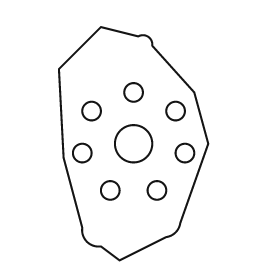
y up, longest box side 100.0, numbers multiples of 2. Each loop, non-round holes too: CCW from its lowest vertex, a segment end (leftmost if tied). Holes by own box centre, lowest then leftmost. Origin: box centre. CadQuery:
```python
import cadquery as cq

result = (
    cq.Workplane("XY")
    .moveTo(-6.0, -50.0)
    .lineTo(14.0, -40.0)
    .threePointArc((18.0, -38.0), (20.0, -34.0))
    .lineTo(32.0, 0.0)
    .lineTo(26.0, 22.0)
    .lineTo(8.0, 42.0)
    .threePointArc((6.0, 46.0), (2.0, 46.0))
    .lineTo(-14.0, 50.0)
    .lineTo(-32.0, 32.0)
    .lineTo(-30.0, -6.0)
    .lineTo(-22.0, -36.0)
    .threePointArc((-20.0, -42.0), (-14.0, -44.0))
    .close()
    .moveTo(-10.0, -20.0)
    .circle(4.0)
    .moveTo(10.0, -20.0)
    .circle(4.0)
    .moveTo(-22.0, -4.0)
    .circle(4.0)
    .moveTo(22.0, -4.0)
    .circle(4.0)
    .moveTo(0.0, 0.0)
    .circle(8.0)
    .moveTo(-18.0, 14.0)
    .circle(4.0)
    .moveTo(18.0, 14.0)
    .circle(4.0)
    .moveTo(0.0, 22.0)
    .circle(4.0)
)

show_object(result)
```